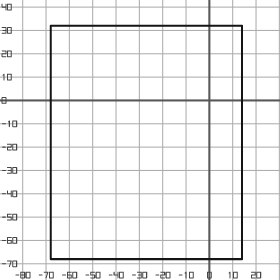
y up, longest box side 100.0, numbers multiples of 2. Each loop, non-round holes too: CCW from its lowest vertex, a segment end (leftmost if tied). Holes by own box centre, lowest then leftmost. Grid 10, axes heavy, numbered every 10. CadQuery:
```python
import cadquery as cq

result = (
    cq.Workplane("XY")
    .moveTo(-68.0, -68.0)
    .lineTo(14.0, -68.0)
    .lineTo(14.0, 32.0)
    .lineTo(-68.0, 32.0)
    .close()
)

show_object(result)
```